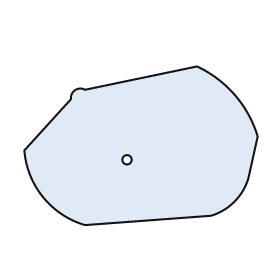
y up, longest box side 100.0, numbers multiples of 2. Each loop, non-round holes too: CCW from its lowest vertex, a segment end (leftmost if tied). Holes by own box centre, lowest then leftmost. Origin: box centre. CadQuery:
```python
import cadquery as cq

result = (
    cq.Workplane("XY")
    .moveTo(-24.0, -34.0)
    .lineTo(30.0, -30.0)
    .threePointArc((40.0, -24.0), (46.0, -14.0))
    .lineTo(50.0, 4.0)
    .threePointArc((40.0, 22.0), (24.0, 34.0))
    .lineTo(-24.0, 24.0)
    .threePointArc((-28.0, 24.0), (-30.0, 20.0))
    .lineTo(-50.0, -2.0)
    .threePointArc((-42.0, -22.0), (-24.0, -34.0))
    .close()
    .moveTo(-6.0, -6.0)
    .circle(2.0)
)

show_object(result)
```